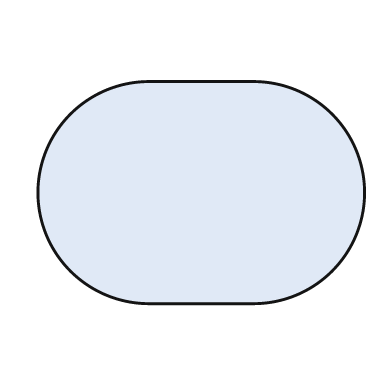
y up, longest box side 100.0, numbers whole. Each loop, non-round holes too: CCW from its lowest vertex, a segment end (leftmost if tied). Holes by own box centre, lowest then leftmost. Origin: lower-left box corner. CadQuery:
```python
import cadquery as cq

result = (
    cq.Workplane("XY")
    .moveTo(34.0, 0.0)
    .lineTo(66.0, 0.0)
    .threePointArc((100.0, 34.0), (66.0, 68.0))
    .lineTo(34.0, 68.0)
    .threePointArc((0.0, 34.0), (34.0, 0.0))
    .close()
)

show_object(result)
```